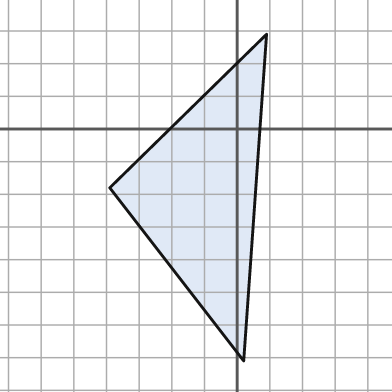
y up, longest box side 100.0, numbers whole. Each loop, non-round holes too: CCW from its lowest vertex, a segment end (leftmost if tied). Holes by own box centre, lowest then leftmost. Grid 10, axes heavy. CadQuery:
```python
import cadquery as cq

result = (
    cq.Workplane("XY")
    .moveTo(2.0, -71.0)
    .lineTo(9.0, 29.0)
    .lineTo(-39.0, -18.0)
    .close()
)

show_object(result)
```